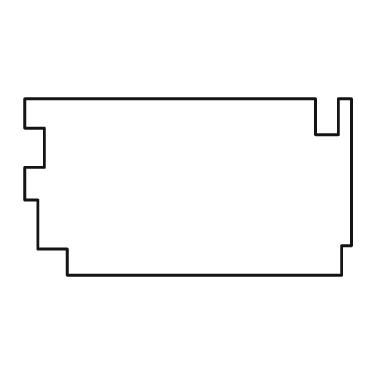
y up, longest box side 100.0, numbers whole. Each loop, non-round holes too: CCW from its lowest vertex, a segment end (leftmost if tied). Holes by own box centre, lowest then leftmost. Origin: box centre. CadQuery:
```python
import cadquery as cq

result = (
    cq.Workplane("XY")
    .moveTo(-37.0, -27.0)
    .lineTo(47.0, -27.0)
    .lineTo(47.0, -18.0)
    .lineTo(50.0, -18.0)
    .lineTo(50.0, 27.0)
    .lineTo(46.0, 27.0)
    .lineTo(46.0, 16.0)
    .lineTo(39.0, 16.0)
    .lineTo(39.0, 27.0)
    .lineTo(-50.0, 27.0)
    .lineTo(-50.0, 18.0)
    .lineTo(-44.0, 18.0)
    .lineTo(-44.0, 6.0)
    .lineTo(-50.0, 6.0)
    .lineTo(-50.0, -4.0)
    .lineTo(-46.0, -4.0)
    .lineTo(-46.0, -19.0)
    .lineTo(-37.0, -19.0)
    .close()
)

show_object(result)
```